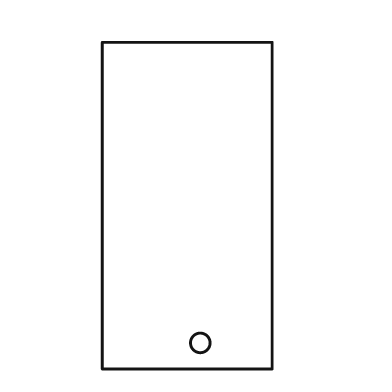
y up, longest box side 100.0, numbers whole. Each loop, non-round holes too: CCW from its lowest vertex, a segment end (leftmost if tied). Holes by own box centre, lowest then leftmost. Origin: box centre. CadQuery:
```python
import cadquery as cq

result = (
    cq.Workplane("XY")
    .moveTo(-26.0, -50.0)
    .lineTo(26.0, -50.0)
    .lineTo(26.0, 50.0)
    .lineTo(-26.0, 50.0)
    .close()
    .moveTo(4.0, -42.0)
    .circle(3.0)
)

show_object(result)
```